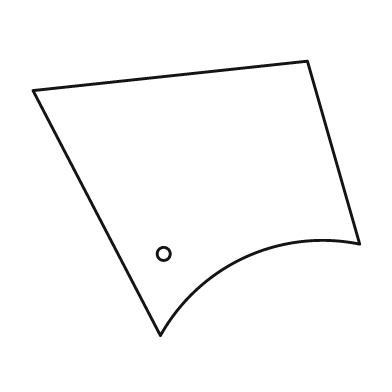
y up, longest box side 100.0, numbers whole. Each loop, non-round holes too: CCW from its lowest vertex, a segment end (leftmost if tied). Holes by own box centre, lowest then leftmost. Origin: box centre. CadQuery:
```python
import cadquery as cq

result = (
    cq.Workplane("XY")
    .moveTo(-11.0, -42.0)
    .threePointArc((15.0, -18.0), (50.0, -14.0))
    .lineTo(34.0, 42.0)
    .lineTo(-50.0, 33.0)
    .close()
    .moveTo(-10.0, -17.0)
    .circle(2.0)
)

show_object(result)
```